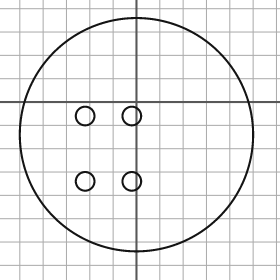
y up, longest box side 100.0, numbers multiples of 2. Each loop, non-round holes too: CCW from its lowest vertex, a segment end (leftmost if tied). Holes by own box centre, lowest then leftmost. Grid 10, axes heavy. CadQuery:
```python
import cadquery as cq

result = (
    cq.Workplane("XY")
    .moveTo(0.0, -14.0)
    .circle(50.0)
    .moveTo(-22.0, -34.0)
    .circle(4.0)
    .moveTo(-2.0, -34.0)
    .circle(4.0)
    .moveTo(-22.0, -6.0)
    .circle(4.0)
    .moveTo(-2.0, -6.0)
    .circle(4.0)
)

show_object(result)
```